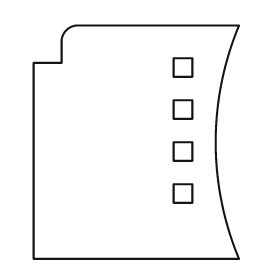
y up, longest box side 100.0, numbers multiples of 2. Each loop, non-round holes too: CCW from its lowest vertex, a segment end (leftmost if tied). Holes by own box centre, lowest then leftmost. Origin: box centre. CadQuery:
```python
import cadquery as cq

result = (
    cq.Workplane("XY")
    .moveTo(-44.0, -50.0)
    .lineTo(44.0, -50.0)
    .threePointArc((34.0, 0.0), (44.0, 50.0))
    .lineTo(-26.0, 50.0)
    .threePointArc((-30.0, 48.0), (-32.0, 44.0))
    .lineTo(-32.0, 34.0)
    .lineTo(-44.0, 34.0)
    .close()
    .moveTo(16.0, -26.0)
    .lineTo(24.0, -26.0)
    .lineTo(24.0, -18.0)
    .lineTo(16.0, -18.0)
    .close()
    .moveTo(16.0, -8.0)
    .lineTo(24.0, -8.0)
    .lineTo(24.0, 0.0)
    .lineTo(16.0, 0.0)
    .close()
    .moveTo(16.0, 10.0)
    .lineTo(24.0, 10.0)
    .lineTo(24.0, 18.0)
    .lineTo(16.0, 18.0)
    .close()
    .moveTo(16.0, 28.0)
    .lineTo(24.0, 28.0)
    .lineTo(24.0, 36.0)
    .lineTo(16.0, 36.0)
    .close()
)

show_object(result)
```